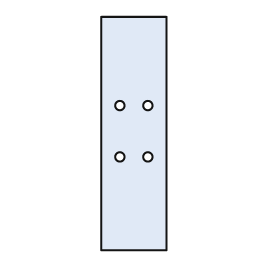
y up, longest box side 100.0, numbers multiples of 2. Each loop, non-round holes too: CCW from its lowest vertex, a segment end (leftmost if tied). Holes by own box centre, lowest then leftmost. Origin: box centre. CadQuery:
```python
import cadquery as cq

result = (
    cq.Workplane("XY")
    .moveTo(-14.0, -50.0)
    .lineTo(14.0, -50.0)
    .lineTo(14.0, 50.0)
    .lineTo(-14.0, 50.0)
    .close()
    .moveTo(-6.0, -10.0)
    .circle(2.0)
    .moveTo(6.0, -10.0)
    .circle(2.0)
    .moveTo(-6.0, 12.0)
    .circle(2.0)
    .moveTo(6.0, 12.0)
    .circle(2.0)
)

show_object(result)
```